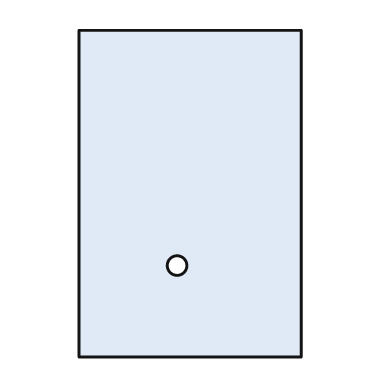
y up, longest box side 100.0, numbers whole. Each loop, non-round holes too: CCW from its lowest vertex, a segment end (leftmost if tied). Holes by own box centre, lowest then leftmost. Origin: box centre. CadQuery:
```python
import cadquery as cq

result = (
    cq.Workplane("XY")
    .moveTo(-34.0, -50.0)
    .lineTo(34.0, -50.0)
    .lineTo(34.0, 50.0)
    .lineTo(-34.0, 50.0)
    .close()
    .moveTo(-4.0, -22.0)
    .circle(3.0)
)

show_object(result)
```